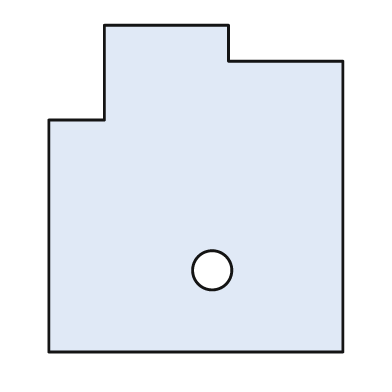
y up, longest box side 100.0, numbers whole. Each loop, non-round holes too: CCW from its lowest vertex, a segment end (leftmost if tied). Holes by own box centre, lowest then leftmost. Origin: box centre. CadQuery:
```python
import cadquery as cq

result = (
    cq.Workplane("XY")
    .moveTo(-45.0, -50.0)
    .lineTo(45.0, -50.0)
    .lineTo(45.0, 39.0)
    .lineTo(10.0, 39.0)
    .lineTo(10.0, 50.0)
    .lineTo(-28.0, 50.0)
    .lineTo(-28.0, 21.0)
    .lineTo(-45.0, 21.0)
    .close()
    .moveTo(5.0, -25.0)
    .circle(6.0)
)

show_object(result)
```